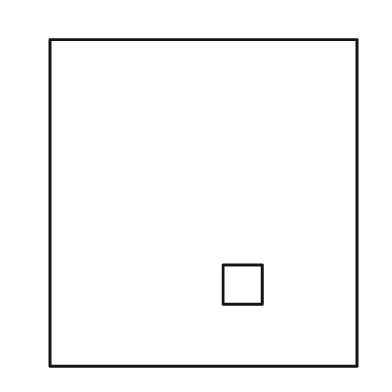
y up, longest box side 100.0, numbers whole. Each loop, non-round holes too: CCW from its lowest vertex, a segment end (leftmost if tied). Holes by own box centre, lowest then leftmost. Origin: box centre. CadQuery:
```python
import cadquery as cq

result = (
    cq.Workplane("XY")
    .moveTo(-47.0, -50.0)
    .lineTo(47.0, -50.0)
    .lineTo(47.0, 50.0)
    .lineTo(-47.0, 50.0)
    .close()
    .moveTo(6.0, -31.0)
    .lineTo(18.0, -31.0)
    .lineTo(18.0, -19.0)
    .lineTo(6.0, -19.0)
    .close()
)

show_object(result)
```